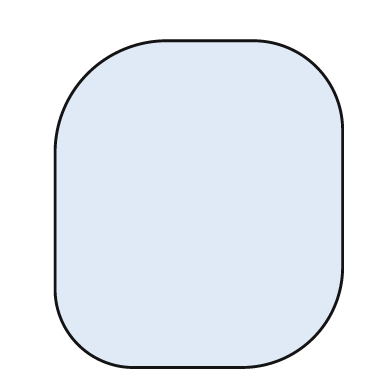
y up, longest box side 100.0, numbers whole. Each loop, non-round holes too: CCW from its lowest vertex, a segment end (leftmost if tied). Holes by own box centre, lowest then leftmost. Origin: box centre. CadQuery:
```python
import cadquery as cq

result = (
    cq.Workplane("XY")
    .moveTo(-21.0, -50.0)
    .lineTo(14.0, -50.0)
    .threePointArc((35.0, -41.0), (44.0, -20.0))
    .lineTo(44.0, 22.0)
    .threePointArc((36.0, 42.0), (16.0, 50.0))
    .lineTo(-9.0, 50.0)
    .threePointArc((-34.0, 40.0), (-44.0, 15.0))
    .lineTo(-44.0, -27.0)
    .threePointArc((-37.0, -43.0), (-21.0, -50.0))
    .close()
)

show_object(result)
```